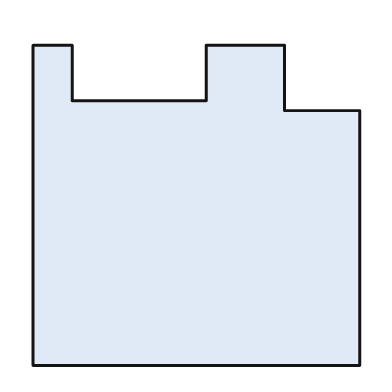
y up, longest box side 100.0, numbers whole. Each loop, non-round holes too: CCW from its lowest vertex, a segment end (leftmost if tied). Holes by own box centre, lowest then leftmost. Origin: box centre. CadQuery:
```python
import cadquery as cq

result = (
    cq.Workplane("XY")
    .moveTo(-50.0, -49.0)
    .lineTo(50.0, -49.0)
    .lineTo(50.0, 29.0)
    .lineTo(27.0, 29.0)
    .lineTo(27.0, 49.0)
    .lineTo(3.0, 49.0)
    .lineTo(3.0, 32.0)
    .lineTo(-38.0, 32.0)
    .lineTo(-38.0, 49.0)
    .lineTo(-50.0, 49.0)
    .close()
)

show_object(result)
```